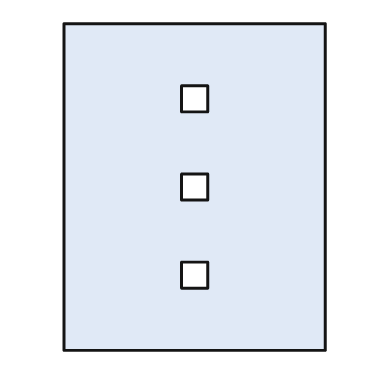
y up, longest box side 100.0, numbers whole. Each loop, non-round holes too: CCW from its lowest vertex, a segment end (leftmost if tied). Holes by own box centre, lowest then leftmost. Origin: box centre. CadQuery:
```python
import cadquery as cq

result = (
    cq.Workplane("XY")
    .moveTo(-40.0, -50.0)
    .lineTo(40.0, -50.0)
    .lineTo(40.0, 50.0)
    .lineTo(-40.0, 50.0)
    .close()
    .moveTo(-4.0, -31.0)
    .lineTo(4.0, -31.0)
    .lineTo(4.0, -23.0)
    .lineTo(-4.0, -23.0)
    .close()
    .moveTo(-4.0, -4.0)
    .lineTo(4.0, -4.0)
    .lineTo(4.0, 4.0)
    .lineTo(-4.0, 4.0)
    .close()
    .moveTo(-4.0, 23.0)
    .lineTo(4.0, 23.0)
    .lineTo(4.0, 31.0)
    .lineTo(-4.0, 31.0)
    .close()
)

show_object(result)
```